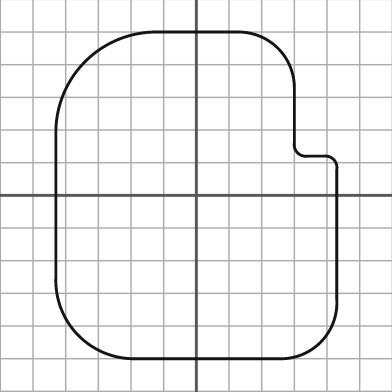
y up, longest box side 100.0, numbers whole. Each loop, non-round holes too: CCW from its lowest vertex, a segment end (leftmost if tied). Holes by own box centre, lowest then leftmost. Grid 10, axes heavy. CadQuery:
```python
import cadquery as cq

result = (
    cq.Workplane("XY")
    .moveTo(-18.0, -50.0)
    .lineTo(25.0, -50.0)
    .threePointArc((38.0, -45.0), (43.0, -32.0))
    .lineTo(43.0, 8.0)
    .threePointArc((42.0, 11.0), (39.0, 12.0))
    .lineTo(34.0, 12.0)
    .threePointArc((31.0, 13.0), (30.0, 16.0))
    .lineTo(30.0, 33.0)
    .threePointArc((25.0, 45.0), (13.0, 50.0))
    .lineTo(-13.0, 50.0)
    .threePointArc((-34.0, 41.0), (-43.0, 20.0))
    .lineTo(-43.0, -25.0)
    .threePointArc((-36.0, -43.0), (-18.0, -50.0))
    .close()
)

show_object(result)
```